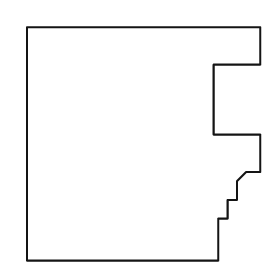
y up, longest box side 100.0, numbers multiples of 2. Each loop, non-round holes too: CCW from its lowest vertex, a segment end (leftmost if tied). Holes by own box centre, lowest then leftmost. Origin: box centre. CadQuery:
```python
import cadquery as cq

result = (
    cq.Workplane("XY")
    .moveTo(-50.0, -50.0)
    .lineTo(32.0, -50.0)
    .lineTo(32.0, -32.0)
    .lineTo(36.0, -32.0)
    .lineTo(36.0, -24.0)
    .lineTo(40.0, -24.0)
    .lineTo(40.0, -16.0)
    .lineTo(44.0, -12.0)
    .lineTo(50.0, -12.0)
    .lineTo(50.0, 4.0)
    .lineTo(30.0, 4.0)
    .lineTo(30.0, 34.0)
    .lineTo(50.0, 34.0)
    .lineTo(50.0, 50.0)
    .lineTo(-50.0, 50.0)
    .close()
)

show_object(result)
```